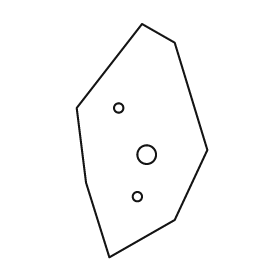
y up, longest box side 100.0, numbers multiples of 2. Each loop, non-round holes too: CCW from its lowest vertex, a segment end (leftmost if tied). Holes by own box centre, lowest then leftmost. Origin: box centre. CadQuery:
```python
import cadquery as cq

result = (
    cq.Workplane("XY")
    .moveTo(-14.0, -50.0)
    .lineTo(14.0, -34.0)
    .lineTo(28.0, -4.0)
    .lineTo(14.0, 42.0)
    .lineTo(0.0, 50.0)
    .lineTo(-28.0, 14.0)
    .lineTo(-24.0, -18.0)
    .close()
    .moveTo(-2.0, -24.0)
    .circle(2.0)
    .moveTo(2.0, -6.0)
    .circle(4.0)
    .moveTo(-10.0, 14.0)
    .circle(2.0)
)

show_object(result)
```